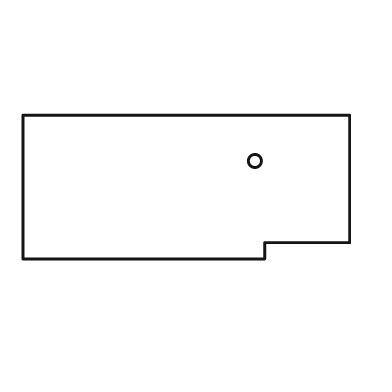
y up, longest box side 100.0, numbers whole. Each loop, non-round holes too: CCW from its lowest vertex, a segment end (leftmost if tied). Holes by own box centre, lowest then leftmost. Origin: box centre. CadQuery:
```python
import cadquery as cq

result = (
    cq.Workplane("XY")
    .moveTo(-50.0, -22.0)
    .lineTo(24.0, -22.0)
    .lineTo(24.0, -17.0)
    .lineTo(50.0, -17.0)
    .lineTo(50.0, 22.0)
    .lineTo(-50.0, 22.0)
    .close()
    .moveTo(21.0, 8.0)
    .circle(2.0)
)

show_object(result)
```